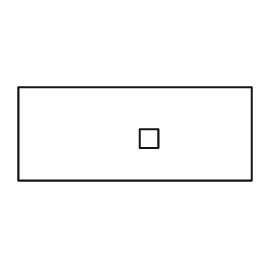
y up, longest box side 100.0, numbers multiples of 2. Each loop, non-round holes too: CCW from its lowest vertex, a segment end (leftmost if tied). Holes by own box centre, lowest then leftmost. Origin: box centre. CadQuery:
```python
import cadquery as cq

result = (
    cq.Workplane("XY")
    .moveTo(-50.0, -20.0)
    .lineTo(50.0, -20.0)
    .lineTo(50.0, 20.0)
    .lineTo(-50.0, 20.0)
    .close()
    .moveTo(2.0, -6.0)
    .lineTo(10.0, -6.0)
    .lineTo(10.0, 2.0)
    .lineTo(2.0, 2.0)
    .close()
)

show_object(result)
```